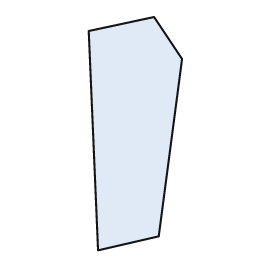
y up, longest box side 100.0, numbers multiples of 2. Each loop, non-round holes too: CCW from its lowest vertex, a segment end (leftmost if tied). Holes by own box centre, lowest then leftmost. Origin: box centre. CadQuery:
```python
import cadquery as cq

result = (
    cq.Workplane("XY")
    .moveTo(-16.0, -50.0)
    .lineTo(10.0, -44.0)
    .lineTo(20.0, 32.0)
    .lineTo(8.0, 50.0)
    .lineTo(-20.0, 44.0)
    .close()
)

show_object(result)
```